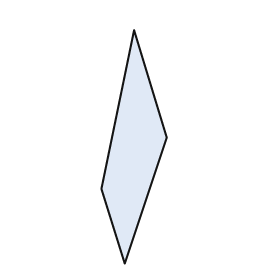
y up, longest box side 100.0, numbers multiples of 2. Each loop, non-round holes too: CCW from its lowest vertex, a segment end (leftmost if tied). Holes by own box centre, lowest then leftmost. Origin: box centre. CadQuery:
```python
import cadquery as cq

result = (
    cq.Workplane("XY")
    .moveTo(-4.0, -50.0)
    .lineTo(14.0, 4.0)
    .lineTo(0.0, 50.0)
    .lineTo(-14.0, -18.0)
    .close()
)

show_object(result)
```